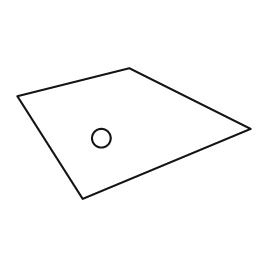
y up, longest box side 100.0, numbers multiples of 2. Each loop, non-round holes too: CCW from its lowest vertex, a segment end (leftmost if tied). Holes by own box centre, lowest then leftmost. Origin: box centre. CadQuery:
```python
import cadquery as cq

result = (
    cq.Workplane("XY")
    .moveTo(-22.0, -28.0)
    .lineTo(50.0, 2.0)
    .lineTo(-2.0, 28.0)
    .lineTo(-50.0, 16.0)
    .close()
    .moveTo(-14.0, -2.0)
    .circle(4.0)
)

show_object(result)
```